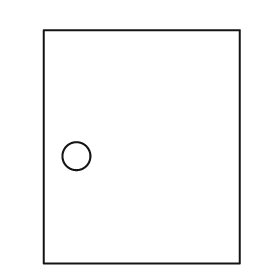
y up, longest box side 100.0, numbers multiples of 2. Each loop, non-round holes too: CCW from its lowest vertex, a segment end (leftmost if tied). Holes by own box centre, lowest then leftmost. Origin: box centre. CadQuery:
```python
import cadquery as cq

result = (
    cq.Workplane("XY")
    .moveTo(-42.0, -50.0)
    .lineTo(42.0, -50.0)
    .lineTo(42.0, 50.0)
    .lineTo(-42.0, 50.0)
    .close()
    .moveTo(-28.0, -4.0)
    .circle(6.0)
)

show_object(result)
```